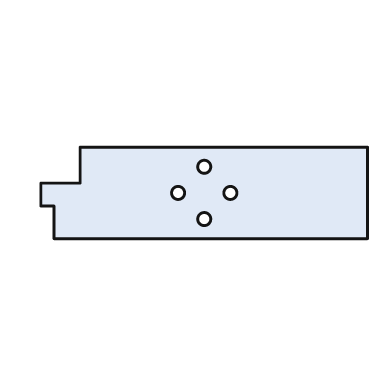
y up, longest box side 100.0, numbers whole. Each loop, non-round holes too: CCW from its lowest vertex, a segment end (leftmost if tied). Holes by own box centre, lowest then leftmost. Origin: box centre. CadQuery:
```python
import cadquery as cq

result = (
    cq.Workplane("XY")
    .moveTo(-46.0, -14.0)
    .lineTo(50.0, -14.0)
    .lineTo(50.0, 14.0)
    .lineTo(-38.0, 14.0)
    .lineTo(-38.0, 3.0)
    .lineTo(-50.0, 3.0)
    .lineTo(-50.0, -4.0)
    .lineTo(-46.0, -4.0)
    .close()
    .moveTo(0.0, -8.0)
    .circle(2.0)
    .moveTo(-8.0, 0.0)
    .circle(2.0)
    .moveTo(8.0, 0.0)
    .circle(2.0)
    .moveTo(0.0, 8.0)
    .circle(2.0)
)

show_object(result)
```